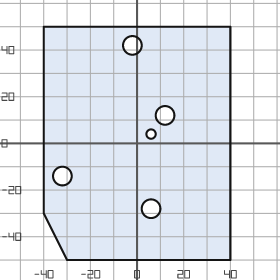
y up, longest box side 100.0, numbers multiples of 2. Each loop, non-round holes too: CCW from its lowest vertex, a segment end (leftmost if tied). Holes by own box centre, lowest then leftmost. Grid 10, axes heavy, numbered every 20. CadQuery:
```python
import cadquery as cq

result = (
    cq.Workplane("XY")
    .moveTo(-30.0, -50.0)
    .lineTo(40.0, -50.0)
    .lineTo(40.0, 50.0)
    .lineTo(-40.0, 50.0)
    .lineTo(-40.0, -30.0)
    .close()
    .moveTo(6.0, -28.0)
    .circle(4.0)
    .moveTo(-32.0, -14.0)
    .circle(4.0)
    .moveTo(6.0, 4.0)
    .circle(2.0)
    .moveTo(12.0, 12.0)
    .circle(4.0)
    .moveTo(-2.0, 42.0)
    .circle(4.0)
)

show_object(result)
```